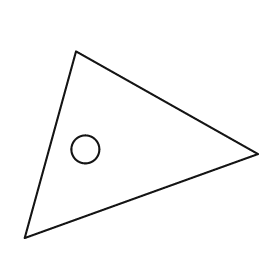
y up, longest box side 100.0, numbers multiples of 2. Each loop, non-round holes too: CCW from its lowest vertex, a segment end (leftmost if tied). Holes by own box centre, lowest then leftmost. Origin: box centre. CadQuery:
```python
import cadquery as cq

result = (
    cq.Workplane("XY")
    .moveTo(-50.0, -40.0)
    .lineTo(50.0, -4.0)
    .lineTo(-28.0, 40.0)
    .close()
    .moveTo(-24.0, -2.0)
    .circle(6.0)
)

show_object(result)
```